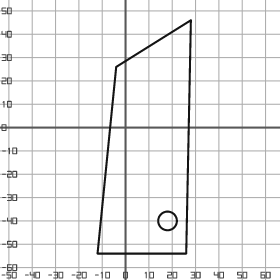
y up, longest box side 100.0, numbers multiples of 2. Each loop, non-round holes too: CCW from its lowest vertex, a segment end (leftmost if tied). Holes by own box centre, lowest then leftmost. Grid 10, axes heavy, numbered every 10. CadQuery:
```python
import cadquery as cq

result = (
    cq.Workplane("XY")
    .moveTo(-12.0, -54.0)
    .lineTo(26.0, -54.0)
    .lineTo(28.0, 46.0)
    .lineTo(-4.0, 26.0)
    .close()
    .moveTo(18.0, -40.0)
    .circle(4.0)
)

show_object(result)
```